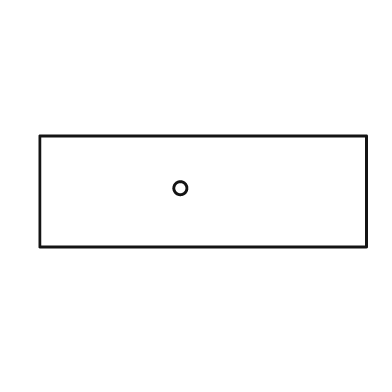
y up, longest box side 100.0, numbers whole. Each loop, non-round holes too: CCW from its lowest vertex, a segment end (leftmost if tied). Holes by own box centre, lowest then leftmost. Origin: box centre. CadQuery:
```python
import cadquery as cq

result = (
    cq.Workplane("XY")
    .moveTo(-50.0, -17.0)
    .lineTo(50.0, -17.0)
    .lineTo(50.0, 17.0)
    .lineTo(-50.0, 17.0)
    .close()
    .moveTo(-7.0, 1.0)
    .circle(2.0)
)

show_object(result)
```